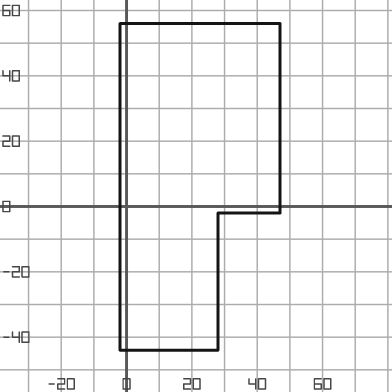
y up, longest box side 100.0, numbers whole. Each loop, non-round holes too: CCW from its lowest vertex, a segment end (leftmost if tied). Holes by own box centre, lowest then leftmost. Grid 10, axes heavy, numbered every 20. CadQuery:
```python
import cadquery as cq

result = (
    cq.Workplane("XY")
    .moveTo(-2.0, -44.0)
    .lineTo(28.0, -44.0)
    .lineTo(28.0, -2.0)
    .lineTo(47.0, -2.0)
    .lineTo(47.0, 56.0)
    .lineTo(-2.0, 56.0)
    .close()
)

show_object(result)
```